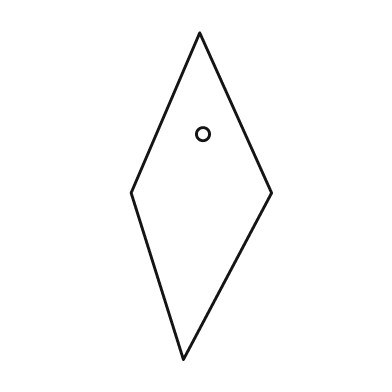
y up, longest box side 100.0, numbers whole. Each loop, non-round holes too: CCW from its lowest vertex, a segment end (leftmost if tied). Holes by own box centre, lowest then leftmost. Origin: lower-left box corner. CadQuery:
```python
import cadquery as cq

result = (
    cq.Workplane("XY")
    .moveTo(16.0, 0.0)
    .lineTo(43.0, 51.0)
    .lineTo(21.0, 100.0)
    .lineTo(0.0, 51.0)
    .close()
    .moveTo(22.0, 69.0)
    .circle(2.0)
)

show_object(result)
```